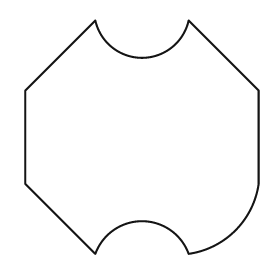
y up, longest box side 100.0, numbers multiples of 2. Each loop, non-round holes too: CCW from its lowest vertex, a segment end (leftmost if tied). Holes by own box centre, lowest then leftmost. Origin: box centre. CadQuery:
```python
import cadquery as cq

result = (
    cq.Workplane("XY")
    .moveTo(-20.0, -50.0)
    .threePointArc((0.0, -36.0), (20.0, -50.0))
    .threePointArc((40.0, -40.0), (50.0, -20.0))
    .lineTo(50.0, 20.0)
    .lineTo(20.0, 50.0)
    .threePointArc((0.0, 34.0), (-20.0, 50.0))
    .lineTo(-50.0, 20.0)
    .lineTo(-50.0, -20.0)
    .close()
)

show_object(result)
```